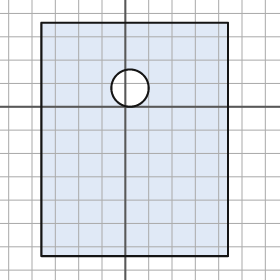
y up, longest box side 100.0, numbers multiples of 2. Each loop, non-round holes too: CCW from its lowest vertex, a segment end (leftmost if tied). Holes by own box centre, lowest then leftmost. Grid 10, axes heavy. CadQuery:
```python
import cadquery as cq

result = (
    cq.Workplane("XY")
    .moveTo(-36.0, -64.0)
    .lineTo(44.0, -64.0)
    .lineTo(44.0, 36.0)
    .lineTo(-36.0, 36.0)
    .close()
    .moveTo(2.0, 8.0)
    .circle(8.0)
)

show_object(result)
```